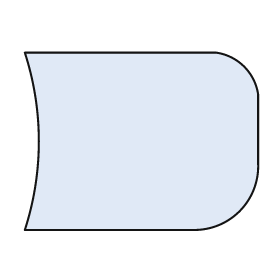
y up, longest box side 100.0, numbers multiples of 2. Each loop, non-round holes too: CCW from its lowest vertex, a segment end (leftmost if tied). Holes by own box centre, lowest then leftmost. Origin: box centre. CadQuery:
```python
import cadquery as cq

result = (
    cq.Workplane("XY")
    .moveTo(-50.0, -38.0)
    .lineTo(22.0, -38.0)
    .threePointArc((42.0, -30.0), (50.0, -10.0))
    .lineTo(50.0, 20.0)
    .threePointArc((44.0, 32.0), (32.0, 38.0))
    .lineTo(-50.0, 38.0)
    .threePointArc((-44.0, 0.0), (-50.0, -38.0))
    .close()
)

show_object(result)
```